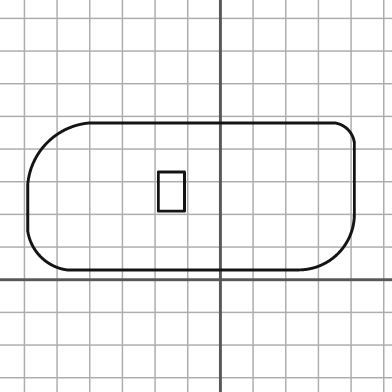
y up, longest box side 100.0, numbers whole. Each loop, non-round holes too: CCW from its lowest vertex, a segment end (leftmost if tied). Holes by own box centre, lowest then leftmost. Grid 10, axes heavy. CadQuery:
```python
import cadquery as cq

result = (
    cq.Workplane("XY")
    .moveTo(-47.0, 3.0)
    .lineTo(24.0, 3.0)
    .threePointArc((36.0, 8.0), (41.0, 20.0))
    .lineTo(41.0, 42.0)
    .threePointArc((39.0, 46.0), (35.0, 48.0))
    .lineTo(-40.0, 48.0)
    .threePointArc((-53.0, 42.0), (-59.0, 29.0))
    .lineTo(-59.0, 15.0)
    .threePointArc((-55.0, 7.0), (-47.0, 3.0))
    .close()
    .moveTo(-19.0, 21.0)
    .lineTo(-11.0, 21.0)
    .lineTo(-11.0, 33.0)
    .lineTo(-19.0, 33.0)
    .close()
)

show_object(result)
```